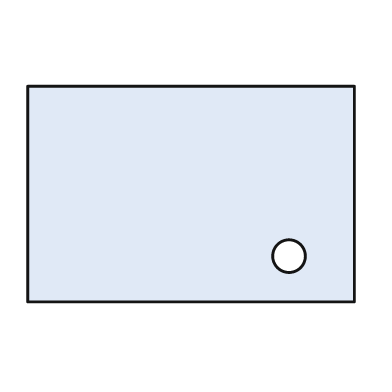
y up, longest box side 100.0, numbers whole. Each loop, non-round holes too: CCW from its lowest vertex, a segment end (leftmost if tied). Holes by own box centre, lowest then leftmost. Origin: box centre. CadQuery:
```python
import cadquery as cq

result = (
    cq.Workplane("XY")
    .moveTo(-50.0, -33.0)
    .lineTo(50.0, -33.0)
    .lineTo(50.0, 33.0)
    .lineTo(-50.0, 33.0)
    .close()
    .moveTo(30.0, -19.0)
    .circle(5.0)
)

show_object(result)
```